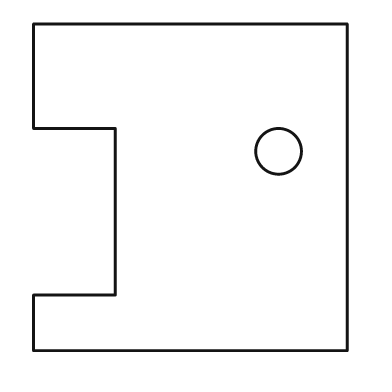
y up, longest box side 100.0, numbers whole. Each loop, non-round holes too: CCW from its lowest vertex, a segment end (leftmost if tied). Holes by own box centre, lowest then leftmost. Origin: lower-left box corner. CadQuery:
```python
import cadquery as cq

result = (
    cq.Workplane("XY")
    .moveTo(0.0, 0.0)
    .lineTo(96.0, 0.0)
    .lineTo(96.0, 100.0)
    .lineTo(0.0, 100.0)
    .lineTo(0.0, 68.0)
    .lineTo(25.0, 68.0)
    .lineTo(25.0, 17.0)
    .lineTo(0.0, 17.0)
    .close()
    .moveTo(75.0, 61.0)
    .circle(7.0)
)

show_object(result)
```